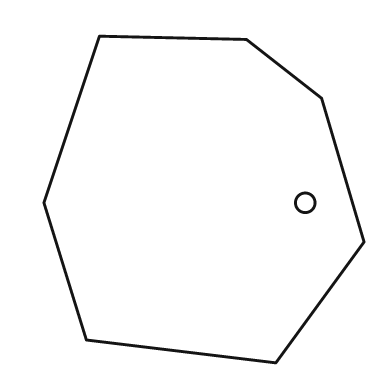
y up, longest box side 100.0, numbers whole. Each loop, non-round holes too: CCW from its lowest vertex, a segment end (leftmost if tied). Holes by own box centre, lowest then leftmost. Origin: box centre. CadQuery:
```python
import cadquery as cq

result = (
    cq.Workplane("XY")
    .moveTo(22.0, -50.0)
    .lineTo(49.0, -13.0)
    .lineTo(36.0, 31.0)
    .lineTo(13.0, 49.0)
    .lineTo(-32.0, 50.0)
    .lineTo(-49.0, -1.0)
    .lineTo(-36.0, -43.0)
    .close()
    .moveTo(31.0, -1.0)
    .circle(3.0)
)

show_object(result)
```